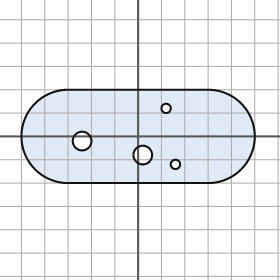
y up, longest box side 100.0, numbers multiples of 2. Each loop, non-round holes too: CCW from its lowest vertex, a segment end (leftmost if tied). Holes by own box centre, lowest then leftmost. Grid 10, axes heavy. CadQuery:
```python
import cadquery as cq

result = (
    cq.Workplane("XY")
    .moveTo(-30.0, -20.0)
    .lineTo(30.0, -20.0)
    .threePointArc((50.0, 0.0), (30.0, 20.0))
    .lineTo(-30.0, 20.0)
    .threePointArc((-50.0, 0.0), (-30.0, -20.0))
    .close()
    .moveTo(16.0, -12.0)
    .circle(2.0)
    .moveTo(2.0, -8.0)
    .circle(4.0)
    .moveTo(-24.0, -2.0)
    .circle(4.0)
    .moveTo(12.0, 12.0)
    .circle(2.0)
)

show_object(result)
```